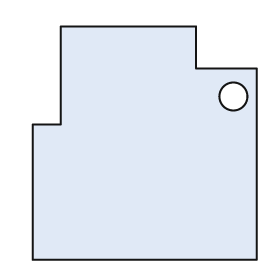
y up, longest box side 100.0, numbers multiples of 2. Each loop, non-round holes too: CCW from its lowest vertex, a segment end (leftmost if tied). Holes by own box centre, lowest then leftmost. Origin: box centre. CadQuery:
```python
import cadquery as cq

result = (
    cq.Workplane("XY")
    .moveTo(-48.0, -50.0)
    .lineTo(48.0, -50.0)
    .lineTo(48.0, 32.0)
    .lineTo(22.0, 32.0)
    .lineTo(22.0, 50.0)
    .lineTo(-36.0, 50.0)
    .lineTo(-36.0, 8.0)
    .lineTo(-48.0, 8.0)
    .close()
    .moveTo(38.0, 20.0)
    .circle(6.0)
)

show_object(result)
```